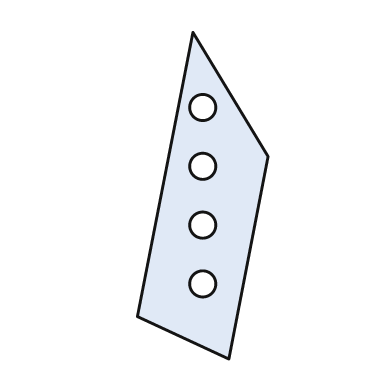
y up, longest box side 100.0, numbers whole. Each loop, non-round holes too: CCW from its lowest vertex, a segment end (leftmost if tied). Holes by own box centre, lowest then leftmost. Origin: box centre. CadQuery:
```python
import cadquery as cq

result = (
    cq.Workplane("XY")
    .moveTo(8.0, -50.0)
    .lineTo(20.0, 12.0)
    .lineTo(-3.0, 50.0)
    .lineTo(-20.0, -37.0)
    .close()
    .moveTo(0.0, -27.0)
    .circle(4.0)
    .moveTo(0.0, -9.0)
    .circle(4.0)
    .moveTo(0.0, 9.0)
    .circle(4.0)
    .moveTo(0.0, 27.0)
    .circle(4.0)
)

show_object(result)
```